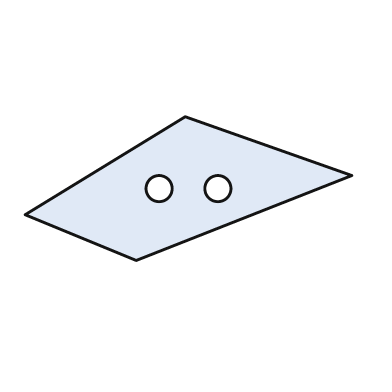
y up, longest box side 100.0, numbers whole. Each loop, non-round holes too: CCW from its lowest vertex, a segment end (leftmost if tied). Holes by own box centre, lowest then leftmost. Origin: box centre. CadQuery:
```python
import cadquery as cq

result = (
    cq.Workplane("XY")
    .moveTo(-16.0, -22.0)
    .lineTo(50.0, 4.0)
    .lineTo(-1.0, 22.0)
    .lineTo(-50.0, -8.0)
    .close()
    .moveTo(-9.0, 0.0)
    .circle(4.0)
    .moveTo(9.0, 0.0)
    .circle(4.0)
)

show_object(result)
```